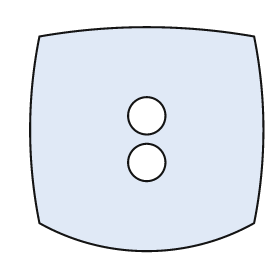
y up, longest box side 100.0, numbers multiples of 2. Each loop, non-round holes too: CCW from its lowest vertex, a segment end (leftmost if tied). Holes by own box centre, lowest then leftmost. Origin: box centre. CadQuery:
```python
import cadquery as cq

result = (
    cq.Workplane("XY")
    .moveTo(-46.0, -36.0)
    .threePointArc((0.0, -48.0), (46.0, -36.0))
    .threePointArc((50.0, 4.0), (46.0, 44.0))
    .threePointArc((0.0, 48.0), (-46.0, 44.0))
    .threePointArc((-50.0, 4.0), (-46.0, -36.0))
    .close()
    .moveTo(0.0, -10.0)
    .circle(8.0)
    .moveTo(0.0, 10.0)
    .circle(8.0)
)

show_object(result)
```